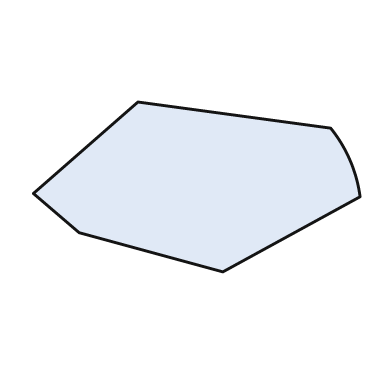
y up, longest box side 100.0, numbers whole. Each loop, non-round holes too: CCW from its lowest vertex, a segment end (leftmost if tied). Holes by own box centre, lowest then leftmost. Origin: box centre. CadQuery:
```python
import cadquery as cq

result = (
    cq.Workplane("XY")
    .moveTo(8.0, -26.0)
    .lineTo(50.0, -3.0)
    .threePointArc((47.0, 8.0), (41.0, 18.0))
    .lineTo(-18.0, 26.0)
    .lineTo(-50.0, -2.0)
    .lineTo(-36.0, -14.0)
    .close()
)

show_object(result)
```